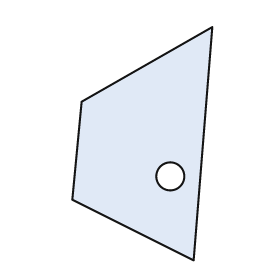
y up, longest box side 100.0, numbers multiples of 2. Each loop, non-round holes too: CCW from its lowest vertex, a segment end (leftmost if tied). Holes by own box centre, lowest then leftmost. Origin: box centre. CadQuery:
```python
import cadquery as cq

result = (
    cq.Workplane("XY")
    .moveTo(22.0, -50.0)
    .lineTo(30.0, 50.0)
    .lineTo(-26.0, 18.0)
    .lineTo(-30.0, -24.0)
    .close()
    .moveTo(12.0, -14.0)
    .circle(6.0)
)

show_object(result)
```